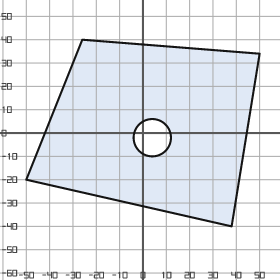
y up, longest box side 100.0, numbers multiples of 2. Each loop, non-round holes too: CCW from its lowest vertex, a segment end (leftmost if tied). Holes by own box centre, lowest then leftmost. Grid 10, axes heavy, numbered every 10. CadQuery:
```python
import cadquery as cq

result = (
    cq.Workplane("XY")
    .moveTo(38.0, -40.0)
    .lineTo(50.0, 34.0)
    .lineTo(-26.0, 40.0)
    .lineTo(-50.0, -20.0)
    .close()
    .moveTo(4.0, -2.0)
    .circle(8.0)
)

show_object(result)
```